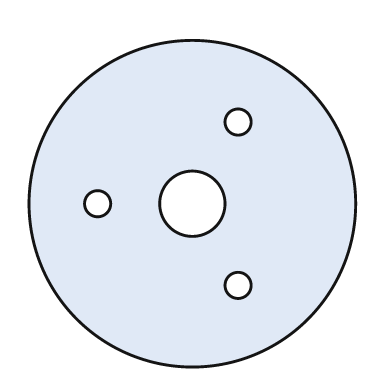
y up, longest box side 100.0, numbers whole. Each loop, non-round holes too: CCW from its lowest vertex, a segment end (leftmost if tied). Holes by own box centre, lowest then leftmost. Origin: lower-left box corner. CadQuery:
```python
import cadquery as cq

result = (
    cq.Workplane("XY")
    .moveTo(50.0, 50.0)
    .circle(50.0)
    .moveTo(64.0, 25.0)
    .circle(4.0)
    .moveTo(21.0, 50.0)
    .circle(4.0)
    .moveTo(50.0, 50.0)
    .circle(10.0)
    .moveTo(64.0, 75.0)
    .circle(4.0)
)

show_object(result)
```